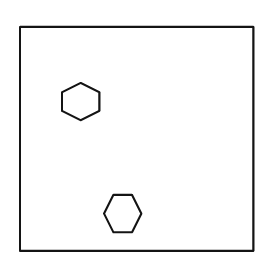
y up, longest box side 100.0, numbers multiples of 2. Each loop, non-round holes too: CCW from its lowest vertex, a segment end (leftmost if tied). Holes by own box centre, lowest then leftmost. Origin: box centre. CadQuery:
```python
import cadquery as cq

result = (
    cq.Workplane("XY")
    .moveTo(-50.0, -48.0)
    .lineTo(50.0, -48.0)
    .lineTo(50.0, 48.0)
    .lineTo(-50.0, 48.0)
    .close()
    .moveTo(-10.0, -40.0)
    .lineTo(-2.0, -40.0)
    .lineTo(2.0, -32.0)
    .lineTo(-2.0, -24.0)
    .lineTo(-10.0, -24.0)
    .lineTo(-14.0, -32.0)
    .close()
    .moveTo(-24.0, 8.0)
    .lineTo(-16.0, 12.0)
    .lineTo(-16.0, 20.0)
    .lineTo(-24.0, 24.0)
    .lineTo(-32.0, 20.0)
    .lineTo(-32.0, 12.0)
    .close()
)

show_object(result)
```